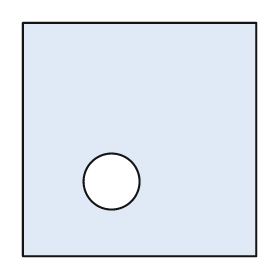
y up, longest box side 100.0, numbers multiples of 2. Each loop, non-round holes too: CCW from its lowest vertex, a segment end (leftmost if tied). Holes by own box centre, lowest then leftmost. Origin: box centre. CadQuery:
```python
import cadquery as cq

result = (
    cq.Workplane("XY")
    .moveTo(-50.0, -50.0)
    .lineTo(50.0, -50.0)
    .lineTo(50.0, 50.0)
    .lineTo(-50.0, 50.0)
    .close()
    .moveTo(-12.0, -18.0)
    .circle(12.0)
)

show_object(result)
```